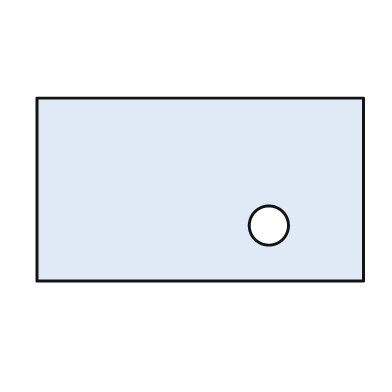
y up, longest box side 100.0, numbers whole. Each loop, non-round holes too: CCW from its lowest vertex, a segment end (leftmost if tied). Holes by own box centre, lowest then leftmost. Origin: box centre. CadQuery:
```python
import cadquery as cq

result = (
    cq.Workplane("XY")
    .moveTo(-50.0, -28.0)
    .lineTo(50.0, -28.0)
    .lineTo(50.0, 28.0)
    .lineTo(-50.0, 28.0)
    .close()
    .moveTo(21.0, -11.0)
    .circle(6.0)
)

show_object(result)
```